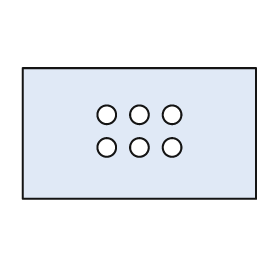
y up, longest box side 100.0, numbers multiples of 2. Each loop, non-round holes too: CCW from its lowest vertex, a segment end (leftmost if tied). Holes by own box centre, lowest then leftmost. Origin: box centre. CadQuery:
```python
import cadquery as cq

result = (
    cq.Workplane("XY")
    .moveTo(-50.0, -28.0)
    .lineTo(50.0, -28.0)
    .lineTo(50.0, 28.0)
    .lineTo(-50.0, 28.0)
    .close()
    .moveTo(-14.0, -6.0)
    .circle(4.0)
    .moveTo(0.0, -6.0)
    .circle(4.0)
    .moveTo(14.0, -6.0)
    .circle(4.0)
    .moveTo(-14.0, 8.0)
    .circle(4.0)
    .moveTo(0.0, 8.0)
    .circle(4.0)
    .moveTo(14.0, 8.0)
    .circle(4.0)
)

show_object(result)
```